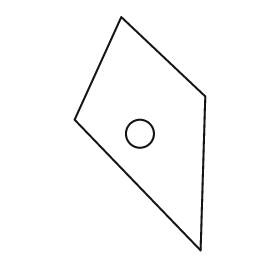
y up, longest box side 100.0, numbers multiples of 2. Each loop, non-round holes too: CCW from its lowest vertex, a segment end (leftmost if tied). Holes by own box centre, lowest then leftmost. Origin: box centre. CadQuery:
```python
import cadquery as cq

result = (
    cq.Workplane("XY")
    .moveTo(26.0, -50.0)
    .lineTo(28.0, 16.0)
    .lineTo(-8.0, 50.0)
    .lineTo(-28.0, 6.0)
    .close()
    .moveTo(0.0, 0.0)
    .circle(6.0)
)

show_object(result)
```